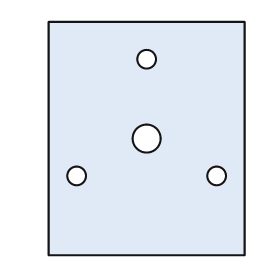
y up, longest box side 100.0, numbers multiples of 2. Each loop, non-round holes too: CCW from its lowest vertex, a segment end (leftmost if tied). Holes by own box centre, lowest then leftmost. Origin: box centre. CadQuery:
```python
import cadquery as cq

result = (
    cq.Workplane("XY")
    .moveTo(-42.0, -50.0)
    .lineTo(42.0, -50.0)
    .lineTo(42.0, 50.0)
    .lineTo(-42.0, 50.0)
    .close()
    .moveTo(-30.0, -16.0)
    .circle(4.0)
    .moveTo(30.0, -16.0)
    .circle(4.0)
    .moveTo(0.0, 0.0)
    .circle(6.0)
    .moveTo(0.0, 34.0)
    .circle(4.0)
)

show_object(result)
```